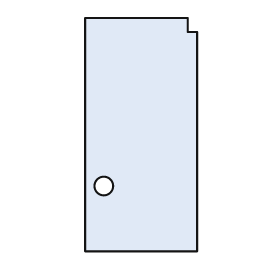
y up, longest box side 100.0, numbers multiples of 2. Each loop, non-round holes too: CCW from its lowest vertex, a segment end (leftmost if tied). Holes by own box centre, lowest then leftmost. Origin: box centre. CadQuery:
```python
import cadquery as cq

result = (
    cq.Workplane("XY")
    .moveTo(-24.0, -50.0)
    .lineTo(24.0, -50.0)
    .lineTo(24.0, 44.0)
    .lineTo(20.0, 44.0)
    .lineTo(20.0, 50.0)
    .lineTo(-24.0, 50.0)
    .close()
    .moveTo(-16.0, -22.0)
    .circle(4.0)
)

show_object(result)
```